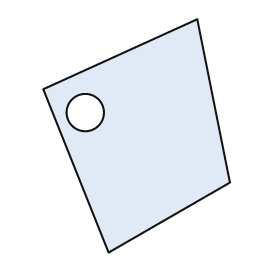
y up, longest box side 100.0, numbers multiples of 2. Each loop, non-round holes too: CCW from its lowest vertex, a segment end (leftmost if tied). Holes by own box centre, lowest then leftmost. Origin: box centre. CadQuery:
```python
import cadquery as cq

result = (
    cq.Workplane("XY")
    .moveTo(-12.0, -50.0)
    .lineTo(40.0, -20.0)
    .lineTo(26.0, 50.0)
    .lineTo(-40.0, 20.0)
    .close()
    .moveTo(-22.0, 10.0)
    .circle(8.0)
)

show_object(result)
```